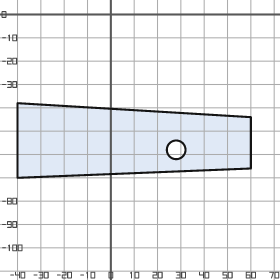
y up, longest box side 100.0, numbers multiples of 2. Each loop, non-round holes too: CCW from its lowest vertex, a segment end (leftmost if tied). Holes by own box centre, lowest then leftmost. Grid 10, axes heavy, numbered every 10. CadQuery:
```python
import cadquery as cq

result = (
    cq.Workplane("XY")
    .moveTo(-40.0, -70.0)
    .lineTo(60.0, -66.0)
    .lineTo(60.0, -44.0)
    .lineTo(-40.0, -38.0)
    .close()
    .moveTo(28.0, -58.0)
    .circle(4.0)
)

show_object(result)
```